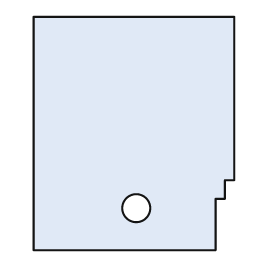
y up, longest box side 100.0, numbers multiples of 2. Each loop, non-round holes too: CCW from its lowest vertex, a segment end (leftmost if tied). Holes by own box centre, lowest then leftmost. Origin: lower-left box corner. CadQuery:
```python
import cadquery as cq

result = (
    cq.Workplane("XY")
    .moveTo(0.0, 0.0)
    .lineTo(78.0, 0.0)
    .lineTo(78.0, 22.0)
    .lineTo(82.0, 22.0)
    .lineTo(82.0, 30.0)
    .lineTo(86.0, 30.0)
    .lineTo(86.0, 100.0)
    .lineTo(0.0, 100.0)
    .close()
    .moveTo(44.0, 18.0)
    .circle(6.0)
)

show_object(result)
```